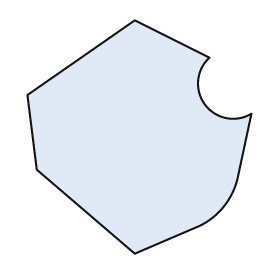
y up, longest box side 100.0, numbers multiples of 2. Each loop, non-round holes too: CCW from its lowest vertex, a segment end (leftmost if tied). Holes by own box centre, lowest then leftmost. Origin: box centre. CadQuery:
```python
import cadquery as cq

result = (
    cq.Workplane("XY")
    .moveTo(-2.0, -50.0)
    .lineTo(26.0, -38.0)
    .threePointArc((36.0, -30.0), (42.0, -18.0))
    .lineTo(48.0, 10.0)
    .threePointArc((28.0, 14.0), (30.0, 34.0))
    .lineTo(-2.0, 50.0)
    .lineTo(-48.0, 18.0)
    .lineTo(-44.0, -14.0)
    .close()
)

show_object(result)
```